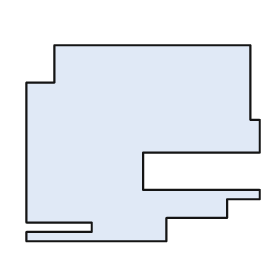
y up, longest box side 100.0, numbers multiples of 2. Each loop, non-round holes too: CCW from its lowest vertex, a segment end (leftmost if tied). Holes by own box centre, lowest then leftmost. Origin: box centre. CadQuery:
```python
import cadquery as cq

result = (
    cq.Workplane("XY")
    .moveTo(-50.0, -42.0)
    .lineTo(10.0, -42.0)
    .lineTo(10.0, -32.0)
    .lineTo(36.0, -32.0)
    .lineTo(36.0, -24.0)
    .lineTo(50.0, -24.0)
    .lineTo(50.0, -20.0)
    .lineTo(0.0, -20.0)
    .lineTo(0.0, -4.0)
    .lineTo(50.0, -4.0)
    .lineTo(50.0, 10.0)
    .lineTo(46.0, 10.0)
    .lineTo(46.0, 42.0)
    .lineTo(-38.0, 42.0)
    .lineTo(-38.0, 26.0)
    .lineTo(-50.0, 26.0)
    .lineTo(-50.0, -34.0)
    .lineTo(-22.0, -34.0)
    .lineTo(-22.0, -38.0)
    .lineTo(-50.0, -38.0)
    .close()
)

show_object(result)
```